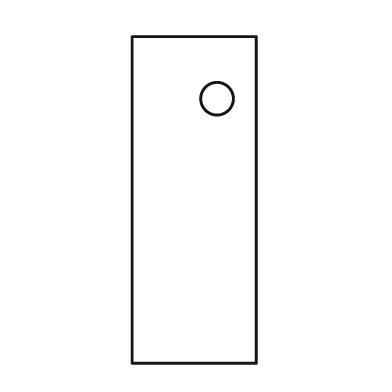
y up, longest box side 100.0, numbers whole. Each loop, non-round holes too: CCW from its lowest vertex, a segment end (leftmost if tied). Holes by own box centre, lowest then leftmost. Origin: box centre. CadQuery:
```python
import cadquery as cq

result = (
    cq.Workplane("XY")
    .moveTo(-19.0, -50.0)
    .lineTo(19.0, -50.0)
    .lineTo(19.0, 50.0)
    .lineTo(-19.0, 50.0)
    .close()
    .moveTo(7.0, 31.0)
    .circle(5.0)
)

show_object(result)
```